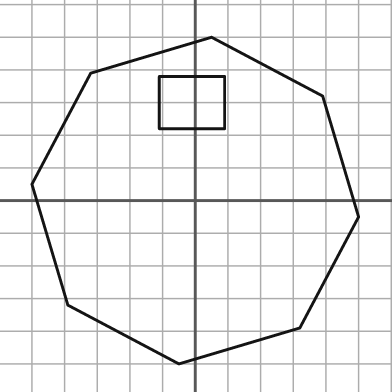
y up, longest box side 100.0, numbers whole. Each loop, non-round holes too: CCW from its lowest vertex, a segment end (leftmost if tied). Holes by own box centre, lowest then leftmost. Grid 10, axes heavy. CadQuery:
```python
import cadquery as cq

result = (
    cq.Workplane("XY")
    .moveTo(-5.0, -50.0)
    .lineTo(32.0, -39.0)
    .lineTo(50.0, -5.0)
    .lineTo(39.0, 32.0)
    .lineTo(5.0, 50.0)
    .lineTo(-32.0, 39.0)
    .lineTo(-50.0, 5.0)
    .lineTo(-39.0, -32.0)
    .close()
    .moveTo(-11.0, 22.0)
    .lineTo(9.0, 22.0)
    .lineTo(9.0, 38.0)
    .lineTo(-11.0, 38.0)
    .close()
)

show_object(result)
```